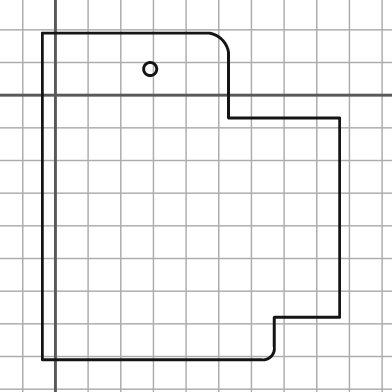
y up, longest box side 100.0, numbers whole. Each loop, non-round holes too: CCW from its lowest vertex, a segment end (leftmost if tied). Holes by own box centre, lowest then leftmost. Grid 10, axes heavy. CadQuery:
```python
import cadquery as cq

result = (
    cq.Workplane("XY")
    .moveTo(-4.0, -81.0)
    .lineTo(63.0, -81.0)
    .threePointArc((66.0, -80.0), (67.0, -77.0))
    .lineTo(67.0, -68.0)
    .lineTo(87.0, -68.0)
    .lineTo(87.0, -7.0)
    .lineTo(53.0, -7.0)
    .lineTo(53.0, 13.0)
    .threePointArc((51.0, 17.0), (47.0, 19.0))
    .lineTo(-4.0, 19.0)
    .close()
    .moveTo(29.0, 8.0)
    .circle(2.0)
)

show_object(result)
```